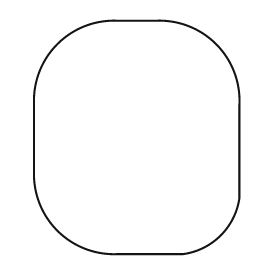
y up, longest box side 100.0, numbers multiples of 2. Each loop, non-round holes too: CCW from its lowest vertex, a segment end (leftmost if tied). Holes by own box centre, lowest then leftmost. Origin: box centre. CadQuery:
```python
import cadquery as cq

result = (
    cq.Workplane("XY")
    .moveTo(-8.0, -50.0)
    .lineTo(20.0, -50.0)
    .threePointArc((36.0, -42.0), (44.0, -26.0))
    .lineTo(44.0, 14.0)
    .threePointArc((34.0, 40.0), (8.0, 50.0))
    .lineTo(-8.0, 50.0)
    .threePointArc((-34.0, 40.0), (-44.0, 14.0))
    .lineTo(-44.0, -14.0)
    .threePointArc((-34.0, -40.0), (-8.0, -50.0))
    .close()
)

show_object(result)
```